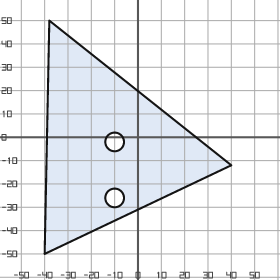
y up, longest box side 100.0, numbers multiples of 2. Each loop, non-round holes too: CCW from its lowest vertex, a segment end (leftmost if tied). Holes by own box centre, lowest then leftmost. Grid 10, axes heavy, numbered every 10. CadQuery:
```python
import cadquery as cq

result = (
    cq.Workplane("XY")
    .moveTo(-40.0, -50.0)
    .lineTo(40.0, -12.0)
    .lineTo(-38.0, 50.0)
    .close()
    .moveTo(-10.0, -26.0)
    .circle(4.0)
    .moveTo(-10.0, -2.0)
    .circle(4.0)
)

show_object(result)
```